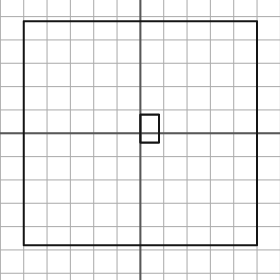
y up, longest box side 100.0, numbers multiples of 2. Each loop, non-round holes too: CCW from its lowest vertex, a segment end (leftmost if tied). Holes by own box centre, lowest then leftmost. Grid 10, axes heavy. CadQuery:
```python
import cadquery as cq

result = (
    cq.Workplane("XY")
    .moveTo(-50.0, -48.0)
    .lineTo(50.0, -48.0)
    .lineTo(50.0, 48.0)
    .lineTo(-50.0, 48.0)
    .close()
    .moveTo(0.0, -4.0)
    .lineTo(8.0, -4.0)
    .lineTo(8.0, 8.0)
    .lineTo(0.0, 8.0)
    .close()
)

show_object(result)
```